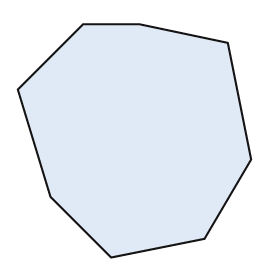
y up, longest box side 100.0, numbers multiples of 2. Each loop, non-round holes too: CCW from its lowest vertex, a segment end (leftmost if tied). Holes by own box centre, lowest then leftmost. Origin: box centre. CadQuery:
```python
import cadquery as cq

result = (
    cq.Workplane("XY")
    .moveTo(-10.0, -50.0)
    .lineTo(30.0, -42.0)
    .lineTo(50.0, -8.0)
    .lineTo(40.0, 42.0)
    .lineTo(2.0, 50.0)
    .lineTo(-22.0, 50.0)
    .lineTo(-50.0, 22.0)
    .lineTo(-36.0, -24.0)
    .close()
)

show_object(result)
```